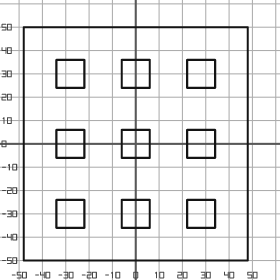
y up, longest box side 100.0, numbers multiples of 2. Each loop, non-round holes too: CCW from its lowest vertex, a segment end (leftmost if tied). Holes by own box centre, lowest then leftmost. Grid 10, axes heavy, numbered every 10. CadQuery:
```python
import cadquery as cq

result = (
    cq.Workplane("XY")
    .moveTo(-48.0, -50.0)
    .lineTo(48.0, -50.0)
    .lineTo(48.0, 50.0)
    .lineTo(-48.0, 50.0)
    .close()
    .moveTo(-34.0, -36.0)
    .lineTo(-22.0, -36.0)
    .lineTo(-22.0, -24.0)
    .lineTo(-34.0, -24.0)
    .close()
    .moveTo(-6.0, -36.0)
    .lineTo(6.0, -36.0)
    .lineTo(6.0, -24.0)
    .lineTo(-6.0, -24.0)
    .close()
    .moveTo(22.0, -36.0)
    .lineTo(34.0, -36.0)
    .lineTo(34.0, -24.0)
    .lineTo(22.0, -24.0)
    .close()
    .moveTo(-34.0, -6.0)
    .lineTo(-22.0, -6.0)
    .lineTo(-22.0, 6.0)
    .lineTo(-34.0, 6.0)
    .close()
    .moveTo(-6.0, -6.0)
    .lineTo(6.0, -6.0)
    .lineTo(6.0, 6.0)
    .lineTo(-6.0, 6.0)
    .close()
    .moveTo(22.0, -6.0)
    .lineTo(34.0, -6.0)
    .lineTo(34.0, 6.0)
    .lineTo(22.0, 6.0)
    .close()
    .moveTo(-34.0, 24.0)
    .lineTo(-22.0, 24.0)
    .lineTo(-22.0, 36.0)
    .lineTo(-34.0, 36.0)
    .close()
    .moveTo(-6.0, 24.0)
    .lineTo(6.0, 24.0)
    .lineTo(6.0, 36.0)
    .lineTo(-6.0, 36.0)
    .close()
    .moveTo(22.0, 24.0)
    .lineTo(34.0, 24.0)
    .lineTo(34.0, 36.0)
    .lineTo(22.0, 36.0)
    .close()
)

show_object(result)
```